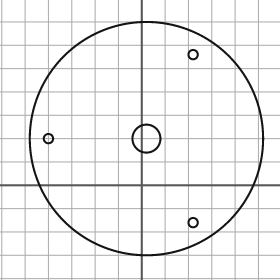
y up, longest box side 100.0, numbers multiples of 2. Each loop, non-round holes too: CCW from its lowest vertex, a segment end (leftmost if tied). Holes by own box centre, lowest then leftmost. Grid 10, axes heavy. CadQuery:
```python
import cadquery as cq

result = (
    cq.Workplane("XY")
    .moveTo(2.0, 20.0)
    .circle(50.0)
    .moveTo(22.0, -16.0)
    .circle(2.0)
    .moveTo(-40.0, 20.0)
    .circle(2.0)
    .moveTo(2.0, 20.0)
    .circle(6.0)
    .moveTo(22.0, 56.0)
    .circle(2.0)
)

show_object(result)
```